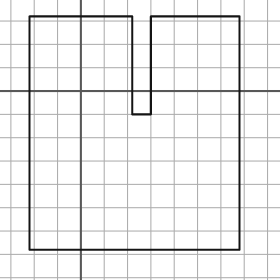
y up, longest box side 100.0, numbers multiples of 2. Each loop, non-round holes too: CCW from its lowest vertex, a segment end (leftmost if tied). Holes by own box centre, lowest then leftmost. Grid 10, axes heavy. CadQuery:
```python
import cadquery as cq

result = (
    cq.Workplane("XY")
    .moveTo(-22.0, -68.0)
    .lineTo(68.0, -68.0)
    .lineTo(68.0, 32.0)
    .lineTo(30.0, 32.0)
    .lineTo(30.0, -10.0)
    .lineTo(22.0, -10.0)
    .lineTo(22.0, 32.0)
    .lineTo(-22.0, 32.0)
    .close()
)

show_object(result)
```